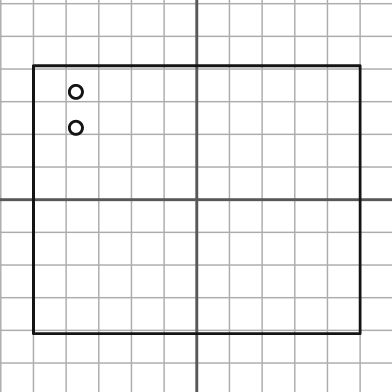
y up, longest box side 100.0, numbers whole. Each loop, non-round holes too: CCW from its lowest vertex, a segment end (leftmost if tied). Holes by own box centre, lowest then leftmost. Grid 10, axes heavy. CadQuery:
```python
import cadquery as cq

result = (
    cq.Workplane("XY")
    .moveTo(-50.0, -41.0)
    .lineTo(50.0, -41.0)
    .lineTo(50.0, 41.0)
    .lineTo(-50.0, 41.0)
    .close()
    .moveTo(-37.0, 22.0)
    .circle(2.0)
    .moveTo(-37.0, 33.0)
    .circle(2.0)
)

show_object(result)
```